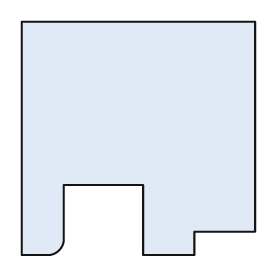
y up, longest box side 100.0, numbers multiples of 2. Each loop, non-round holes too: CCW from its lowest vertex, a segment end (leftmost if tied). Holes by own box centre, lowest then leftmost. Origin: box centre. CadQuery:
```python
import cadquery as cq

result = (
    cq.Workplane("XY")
    .moveTo(-50.0, -50.0)
    .lineTo(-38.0, -50.0)
    .threePointArc((-34.0, -48.0), (-32.0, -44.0))
    .lineTo(-32.0, -20.0)
    .lineTo(2.0, -20.0)
    .lineTo(2.0, -50.0)
    .lineTo(24.0, -50.0)
    .lineTo(24.0, -40.0)
    .lineTo(50.0, -40.0)
    .lineTo(50.0, 50.0)
    .lineTo(-50.0, 50.0)
    .close()
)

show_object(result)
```